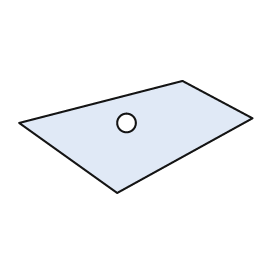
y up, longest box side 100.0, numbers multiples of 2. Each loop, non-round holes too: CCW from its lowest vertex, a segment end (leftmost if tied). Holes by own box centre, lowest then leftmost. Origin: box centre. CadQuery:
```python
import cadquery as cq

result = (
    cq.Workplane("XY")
    .moveTo(-8.0, -24.0)
    .lineTo(50.0, 8.0)
    .lineTo(20.0, 24.0)
    .lineTo(-50.0, 6.0)
    .close()
    .moveTo(-4.0, 6.0)
    .circle(4.0)
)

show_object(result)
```